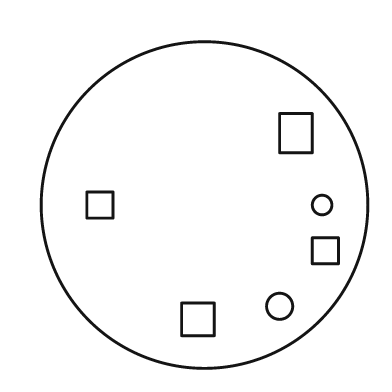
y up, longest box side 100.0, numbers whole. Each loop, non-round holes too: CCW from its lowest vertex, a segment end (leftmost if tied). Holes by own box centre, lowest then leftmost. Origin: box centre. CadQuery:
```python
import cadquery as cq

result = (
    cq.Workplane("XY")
    .moveTo(0.0, 0.0)
    .circle(50.0)
    .moveTo(-7.0, -40.0)
    .lineTo(3.0, -40.0)
    .lineTo(3.0, -30.0)
    .lineTo(-7.0, -30.0)
    .close()
    .moveTo(23.0, -31.0)
    .circle(4.0)
    .moveTo(33.0, -18.0)
    .lineTo(41.0, -18.0)
    .lineTo(41.0, -10.0)
    .lineTo(33.0, -10.0)
    .close()
    .moveTo(-36.0, -4.0)
    .lineTo(-28.0, -4.0)
    .lineTo(-28.0, 4.0)
    .lineTo(-36.0, 4.0)
    .close()
    .moveTo(36.0, 0.0)
    .circle(3.0)
    .moveTo(23.0, 16.0)
    .lineTo(33.0, 16.0)
    .lineTo(33.0, 28.0)
    .lineTo(23.0, 28.0)
    .close()
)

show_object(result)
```